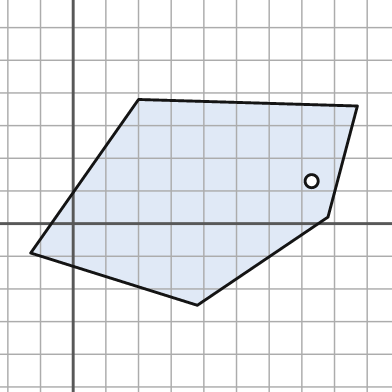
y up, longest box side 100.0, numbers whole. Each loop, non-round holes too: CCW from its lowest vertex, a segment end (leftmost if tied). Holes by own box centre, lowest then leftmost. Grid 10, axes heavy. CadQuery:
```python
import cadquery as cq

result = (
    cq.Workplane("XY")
    .moveTo(38.0, -25.0)
    .lineTo(78.0, 2.0)
    .lineTo(87.0, 36.0)
    .lineTo(20.0, 38.0)
    .lineTo(-13.0, -9.0)
    .close()
    .moveTo(73.0, 13.0)
    .circle(2.0)
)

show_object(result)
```